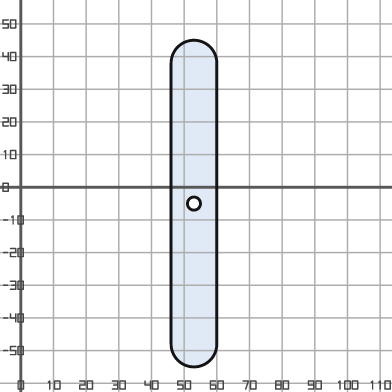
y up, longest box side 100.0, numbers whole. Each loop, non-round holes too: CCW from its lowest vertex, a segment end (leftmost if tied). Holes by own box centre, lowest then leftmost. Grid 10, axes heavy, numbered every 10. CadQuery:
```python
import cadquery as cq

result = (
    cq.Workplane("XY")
    .moveTo(46.0, -48.0)
    .threePointArc((53.0, -55.0), (60.0, -48.0))
    .lineTo(60.0, 38.0)
    .threePointArc((53.0, 45.0), (46.0, 38.0))
    .close()
    .moveTo(53.0, -5.0)
    .circle(2.0)
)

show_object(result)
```